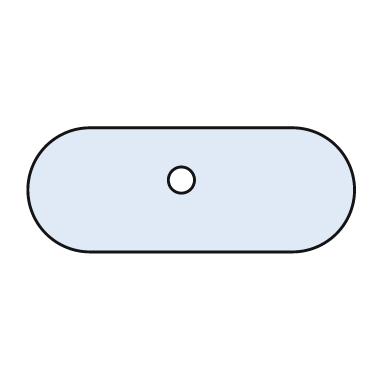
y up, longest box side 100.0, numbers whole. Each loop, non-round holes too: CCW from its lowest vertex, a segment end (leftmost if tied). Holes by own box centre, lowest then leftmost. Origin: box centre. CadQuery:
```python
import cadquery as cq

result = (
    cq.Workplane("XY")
    .moveTo(-31.0, -19.0)
    .lineTo(31.0, -19.0)
    .threePointArc((50.0, 0.0), (31.0, 19.0))
    .lineTo(-31.0, 19.0)
    .threePointArc((-50.0, 0.0), (-31.0, -19.0))
    .close()
    .moveTo(-3.0, 3.0)
    .circle(4.0)
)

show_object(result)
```